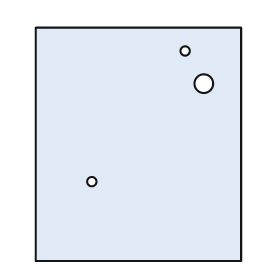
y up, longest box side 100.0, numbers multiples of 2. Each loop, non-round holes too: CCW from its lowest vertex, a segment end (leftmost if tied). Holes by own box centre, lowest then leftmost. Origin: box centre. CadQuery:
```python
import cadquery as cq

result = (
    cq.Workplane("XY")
    .moveTo(-44.0, -50.0)
    .lineTo(44.0, -50.0)
    .lineTo(44.0, 50.0)
    .lineTo(-44.0, 50.0)
    .close()
    .moveTo(-20.0, -16.0)
    .circle(2.0)
    .moveTo(28.0, 26.0)
    .circle(4.0)
    .moveTo(20.0, 40.0)
    .circle(2.0)
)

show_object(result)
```